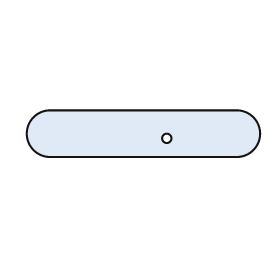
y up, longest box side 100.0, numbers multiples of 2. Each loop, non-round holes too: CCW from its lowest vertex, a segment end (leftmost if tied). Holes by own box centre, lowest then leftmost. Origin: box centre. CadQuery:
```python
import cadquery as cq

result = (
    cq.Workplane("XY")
    .moveTo(-40.0, -10.0)
    .lineTo(40.0, -10.0)
    .threePointArc((50.0, 0.0), (40.0, 10.0))
    .lineTo(-40.0, 10.0)
    .threePointArc((-50.0, 0.0), (-40.0, -10.0))
    .close()
    .moveTo(10.0, -2.0)
    .circle(2.0)
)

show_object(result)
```